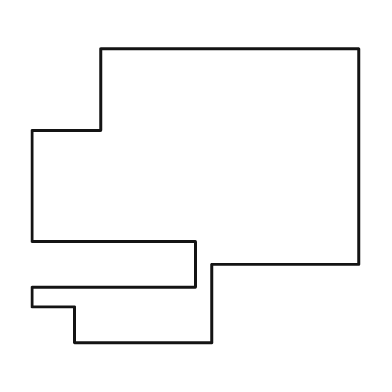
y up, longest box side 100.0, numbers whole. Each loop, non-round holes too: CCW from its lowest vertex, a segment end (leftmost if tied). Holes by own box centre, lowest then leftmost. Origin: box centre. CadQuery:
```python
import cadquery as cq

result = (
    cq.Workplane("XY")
    .moveTo(-37.0, -45.0)
    .lineTo(5.0, -45.0)
    .lineTo(5.0, -21.0)
    .lineTo(50.0, -21.0)
    .lineTo(50.0, 45.0)
    .lineTo(-29.0, 45.0)
    .lineTo(-29.0, 20.0)
    .lineTo(-50.0, 20.0)
    .lineTo(-50.0, -14.0)
    .lineTo(0.0, -14.0)
    .lineTo(0.0, -28.0)
    .lineTo(-50.0, -28.0)
    .lineTo(-50.0, -34.0)
    .lineTo(-37.0, -34.0)
    .close()
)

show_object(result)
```